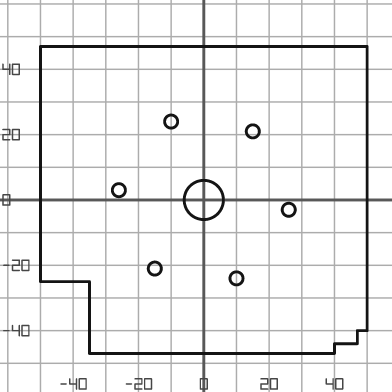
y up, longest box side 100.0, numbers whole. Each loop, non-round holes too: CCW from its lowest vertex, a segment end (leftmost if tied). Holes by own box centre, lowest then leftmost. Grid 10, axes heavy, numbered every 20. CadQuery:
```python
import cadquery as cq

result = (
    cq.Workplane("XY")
    .moveTo(-35.0, -47.0)
    .lineTo(40.0, -47.0)
    .lineTo(40.0, -44.0)
    .lineTo(47.0, -44.0)
    .lineTo(47.0, -40.0)
    .lineTo(50.0, -40.0)
    .lineTo(50.0, 47.0)
    .lineTo(-50.0, 47.0)
    .lineTo(-50.0, -25.0)
    .lineTo(-35.0, -25.0)
    .close()
    .moveTo(10.0, -24.0)
    .circle(2.0)
    .moveTo(-15.0, -21.0)
    .circle(2.0)
    .moveTo(26.0, -3.0)
    .circle(2.0)
    .moveTo(0.0, 0.0)
    .circle(6.0)
    .moveTo(-26.0, 3.0)
    .circle(2.0)
    .moveTo(15.0, 21.0)
    .circle(2.0)
    .moveTo(-10.0, 24.0)
    .circle(2.0)
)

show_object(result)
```